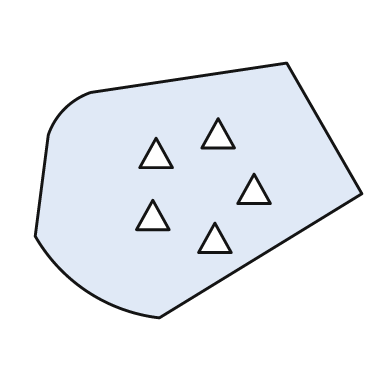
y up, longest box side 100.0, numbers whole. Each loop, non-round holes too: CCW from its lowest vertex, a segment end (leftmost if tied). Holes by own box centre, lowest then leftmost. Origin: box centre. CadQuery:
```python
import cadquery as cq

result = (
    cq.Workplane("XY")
    .moveTo(-12.0, -39.0)
    .lineTo(50.0, -1.0)
    .lineTo(27.0, 39.0)
    .lineTo(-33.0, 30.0)
    .threePointArc((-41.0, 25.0), (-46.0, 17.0))
    .lineTo(-50.0, -14.0)
    .threePointArc((-34.0, -31.0), (-12.0, -39.0))
    .close()
    .moveTo(0.0, -19.0)
    .lineTo(10.0, -19.0)
    .lineTo(5.0, -10.0)
    .close()
    .moveTo(-19.0, -12.0)
    .lineTo(-9.0, -12.0)
    .lineTo(-14.0, -3.0)
    .close()
    .moveTo(12.0, -4.0)
    .lineTo(22.0, -4.0)
    .lineTo(17.0, 5.0)
    .close()
    .moveTo(-18.0, 7.0)
    .lineTo(-8.0, 7.0)
    .lineTo(-13.0, 16.0)
    .close()
    .moveTo(1.0, 13.0)
    .lineTo(11.0, 13.0)
    .lineTo(6.0, 22.0)
    .close()
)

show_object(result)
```